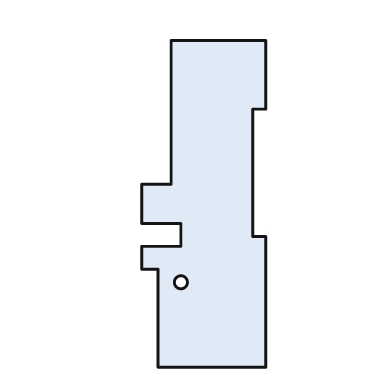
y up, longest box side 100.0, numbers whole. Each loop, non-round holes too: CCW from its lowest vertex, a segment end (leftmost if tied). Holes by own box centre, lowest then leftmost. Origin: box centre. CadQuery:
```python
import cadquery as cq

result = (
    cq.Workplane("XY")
    .moveTo(-14.0, -50.0)
    .lineTo(19.0, -50.0)
    .lineTo(19.0, -10.0)
    .lineTo(15.0, -10.0)
    .lineTo(15.0, 29.0)
    .lineTo(19.0, 29.0)
    .lineTo(19.0, 50.0)
    .lineTo(-10.0, 50.0)
    .lineTo(-10.0, 6.0)
    .lineTo(-19.0, 6.0)
    .lineTo(-19.0, -6.0)
    .lineTo(-7.0, -6.0)
    .lineTo(-7.0, -13.0)
    .lineTo(-19.0, -13.0)
    .lineTo(-19.0, -20.0)
    .lineTo(-14.0, -20.0)
    .close()
    .moveTo(-7.0, -24.0)
    .circle(2.0)
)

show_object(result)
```